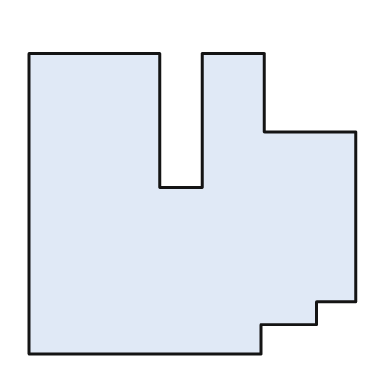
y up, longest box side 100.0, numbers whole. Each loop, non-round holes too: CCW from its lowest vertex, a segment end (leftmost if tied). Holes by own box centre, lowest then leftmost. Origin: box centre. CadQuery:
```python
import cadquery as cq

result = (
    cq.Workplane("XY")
    .moveTo(-50.0, -46.0)
    .lineTo(21.0, -46.0)
    .lineTo(21.0, -37.0)
    .lineTo(38.0, -37.0)
    .lineTo(38.0, -30.0)
    .lineTo(50.0, -30.0)
    .lineTo(50.0, 22.0)
    .lineTo(22.0, 22.0)
    .lineTo(22.0, 46.0)
    .lineTo(3.0, 46.0)
    .lineTo(3.0, 5.0)
    .lineTo(-10.0, 5.0)
    .lineTo(-10.0, 46.0)
    .lineTo(-50.0, 46.0)
    .close()
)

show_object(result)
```